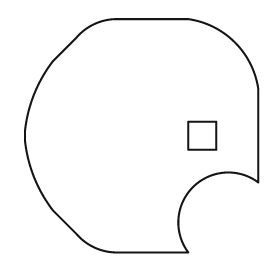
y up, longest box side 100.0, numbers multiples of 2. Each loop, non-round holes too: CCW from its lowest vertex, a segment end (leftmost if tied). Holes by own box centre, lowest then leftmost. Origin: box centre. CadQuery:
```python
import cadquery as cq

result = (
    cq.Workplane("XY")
    .moveTo(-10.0, -50.0)
    .lineTo(20.0, -50.0)
    .threePointArc((22.0, -22.0), (50.0, -20.0))
    .lineTo(50.0, 20.0)
    .threePointArc((40.0, 40.0), (20.0, 50.0))
    .lineTo(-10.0, 50.0)
    .threePointArc((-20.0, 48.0), (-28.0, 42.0))
    .lineTo(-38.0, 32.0)
    .threePointArc((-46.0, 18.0), (-50.0, 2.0))
    .lineTo(-50.0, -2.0)
    .threePointArc((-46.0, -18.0), (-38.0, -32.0))
    .lineTo(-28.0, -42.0)
    .threePointArc((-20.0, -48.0), (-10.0, -50.0))
    .close()
    .moveTo(20.0, -6.0)
    .lineTo(32.0, -6.0)
    .lineTo(32.0, 6.0)
    .lineTo(20.0, 6.0)
    .close()
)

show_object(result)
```